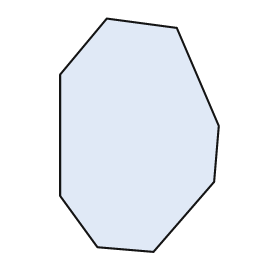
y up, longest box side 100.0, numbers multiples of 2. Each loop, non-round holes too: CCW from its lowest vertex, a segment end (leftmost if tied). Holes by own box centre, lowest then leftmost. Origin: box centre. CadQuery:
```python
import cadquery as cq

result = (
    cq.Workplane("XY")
    .moveTo(6.0, -50.0)
    .lineTo(32.0, -20.0)
    .lineTo(34.0, 4.0)
    .lineTo(16.0, 46.0)
    .lineTo(-14.0, 50.0)
    .lineTo(-34.0, 26.0)
    .lineTo(-34.0, -26.0)
    .lineTo(-18.0, -48.0)
    .close()
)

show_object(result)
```